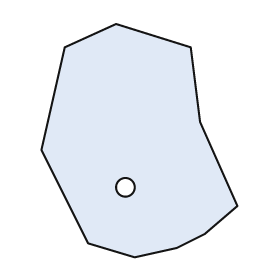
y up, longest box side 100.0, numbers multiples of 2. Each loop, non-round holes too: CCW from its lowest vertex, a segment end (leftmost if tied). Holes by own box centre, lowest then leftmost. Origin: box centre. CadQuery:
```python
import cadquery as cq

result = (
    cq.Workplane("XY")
    .moveTo(-2.0, -50.0)
    .lineTo(16.0, -46.0)
    .lineTo(28.0, -40.0)
    .lineTo(42.0, -28.0)
    .lineTo(26.0, 8.0)
    .lineTo(22.0, 40.0)
    .lineTo(-10.0, 50.0)
    .lineTo(-32.0, 40.0)
    .lineTo(-42.0, -4.0)
    .lineTo(-22.0, -44.0)
    .close()
    .moveTo(-6.0, -20.0)
    .circle(4.0)
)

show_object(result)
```